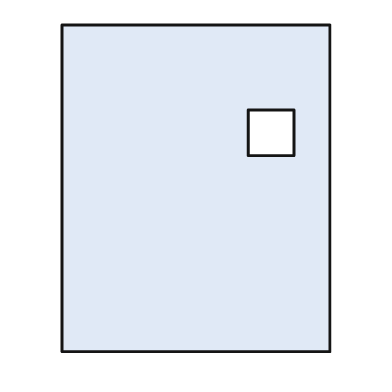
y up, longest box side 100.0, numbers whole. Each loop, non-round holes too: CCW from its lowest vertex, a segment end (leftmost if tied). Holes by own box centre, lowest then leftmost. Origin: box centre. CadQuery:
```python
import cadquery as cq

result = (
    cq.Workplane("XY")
    .moveTo(-41.0, -50.0)
    .lineTo(41.0, -50.0)
    .lineTo(41.0, 50.0)
    .lineTo(-41.0, 50.0)
    .close()
    .moveTo(16.0, 10.0)
    .lineTo(30.0, 10.0)
    .lineTo(30.0, 24.0)
    .lineTo(16.0, 24.0)
    .close()
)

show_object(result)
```